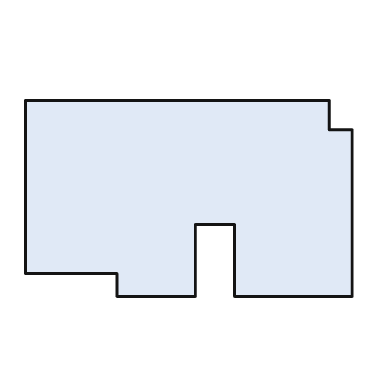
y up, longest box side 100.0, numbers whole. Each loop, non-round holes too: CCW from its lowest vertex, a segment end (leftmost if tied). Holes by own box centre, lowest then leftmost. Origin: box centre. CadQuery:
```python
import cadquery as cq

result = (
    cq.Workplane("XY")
    .moveTo(-22.0, -30.0)
    .lineTo(2.0, -30.0)
    .lineTo(2.0, -8.0)
    .lineTo(14.0, -8.0)
    .lineTo(14.0, -30.0)
    .lineTo(50.0, -30.0)
    .lineTo(50.0, 21.0)
    .lineTo(43.0, 21.0)
    .lineTo(43.0, 30.0)
    .lineTo(-50.0, 30.0)
    .lineTo(-50.0, -23.0)
    .lineTo(-22.0, -23.0)
    .close()
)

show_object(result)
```